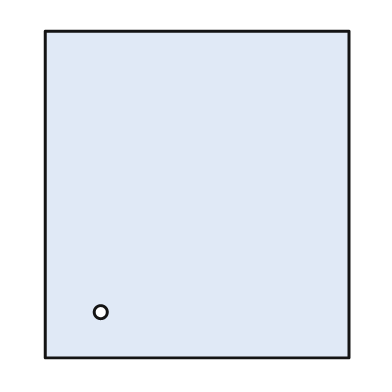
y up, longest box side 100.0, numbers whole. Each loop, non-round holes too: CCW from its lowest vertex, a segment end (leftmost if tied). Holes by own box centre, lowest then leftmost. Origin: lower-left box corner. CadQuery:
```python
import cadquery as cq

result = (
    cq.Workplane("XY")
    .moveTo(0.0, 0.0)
    .lineTo(93.0, 0.0)
    .lineTo(93.0, 100.0)
    .lineTo(0.0, 100.0)
    .close()
    .moveTo(17.0, 14.0)
    .circle(2.0)
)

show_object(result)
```